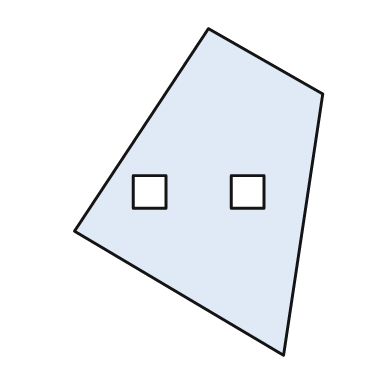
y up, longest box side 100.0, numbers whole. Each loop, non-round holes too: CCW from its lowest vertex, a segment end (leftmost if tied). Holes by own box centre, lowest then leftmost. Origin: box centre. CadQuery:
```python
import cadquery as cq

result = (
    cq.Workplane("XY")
    .moveTo(26.0, -50.0)
    .lineTo(38.0, 30.0)
    .lineTo(3.0, 50.0)
    .lineTo(-38.0, -12.0)
    .close()
    .moveTo(-20.0, -5.0)
    .lineTo(-10.0, -5.0)
    .lineTo(-10.0, 5.0)
    .lineTo(-20.0, 5.0)
    .close()
    .moveTo(10.0, -5.0)
    .lineTo(20.0, -5.0)
    .lineTo(20.0, 5.0)
    .lineTo(10.0, 5.0)
    .close()
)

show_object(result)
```